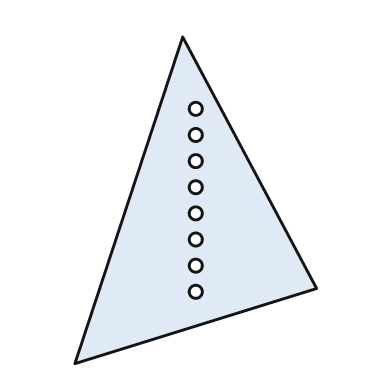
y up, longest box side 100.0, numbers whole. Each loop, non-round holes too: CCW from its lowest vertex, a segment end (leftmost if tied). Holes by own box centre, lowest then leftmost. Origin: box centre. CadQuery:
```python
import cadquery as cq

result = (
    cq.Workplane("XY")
    .moveTo(-37.0, -50.0)
    .lineTo(37.0, -27.0)
    .lineTo(-4.0, 50.0)
    .close()
    .moveTo(0.0, -28.0)
    .circle(2.0)
    .moveTo(0.0, -20.0)
    .circle(2.0)
    .moveTo(0.0, -12.0)
    .circle(2.0)
    .moveTo(0.0, -4.0)
    .circle(2.0)
    .moveTo(0.0, 4.0)
    .circle(2.0)
    .moveTo(0.0, 12.0)
    .circle(2.0)
    .moveTo(0.0, 20.0)
    .circle(2.0)
    .moveTo(0.0, 28.0)
    .circle(2.0)
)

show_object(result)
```